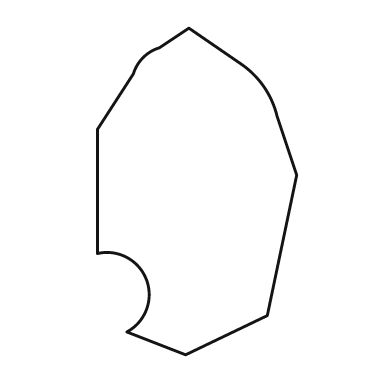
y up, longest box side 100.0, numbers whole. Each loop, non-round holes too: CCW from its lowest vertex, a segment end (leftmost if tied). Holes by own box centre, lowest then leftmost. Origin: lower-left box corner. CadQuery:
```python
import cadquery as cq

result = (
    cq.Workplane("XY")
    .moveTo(27.0, 0.0)
    .lineTo(52.0, 12.0)
    .lineTo(61.0, 55.0)
    .lineTo(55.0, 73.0)
    .threePointArc((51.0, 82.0), (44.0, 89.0))
    .lineTo(28.0, 100.0)
    .lineTo(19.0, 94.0)
    .threePointArc((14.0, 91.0), (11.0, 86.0))
    .lineTo(0.0, 69.0)
    .lineTo(0.0, 31.0)
    .threePointArc((15.0, 23.0), (9.0, 7.0))
    .close()
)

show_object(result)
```